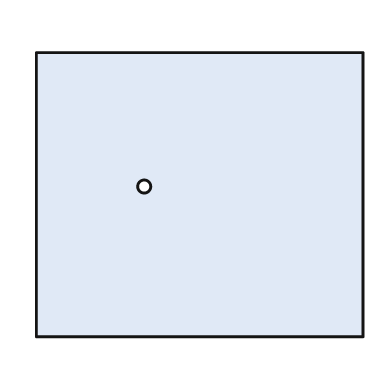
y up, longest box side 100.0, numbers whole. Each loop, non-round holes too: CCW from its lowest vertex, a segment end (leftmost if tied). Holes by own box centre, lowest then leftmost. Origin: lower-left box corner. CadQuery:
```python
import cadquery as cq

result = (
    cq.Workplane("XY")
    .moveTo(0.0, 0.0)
    .lineTo(100.0, 0.0)
    .lineTo(100.0, 87.0)
    .lineTo(0.0, 87.0)
    .close()
    .moveTo(33.0, 46.0)
    .circle(2.0)
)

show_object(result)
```